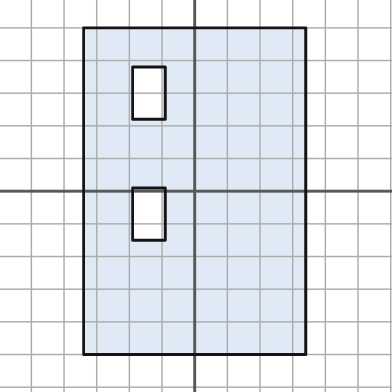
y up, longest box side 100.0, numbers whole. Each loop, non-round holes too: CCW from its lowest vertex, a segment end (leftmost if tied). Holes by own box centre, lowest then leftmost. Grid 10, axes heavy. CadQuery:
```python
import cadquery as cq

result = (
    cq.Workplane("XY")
    .moveTo(-34.0, -50.0)
    .lineTo(34.0, -50.0)
    .lineTo(34.0, 50.0)
    .lineTo(-34.0, 50.0)
    .close()
    .moveTo(-19.0, -15.0)
    .lineTo(-9.0, -15.0)
    .lineTo(-9.0, 1.0)
    .lineTo(-19.0, 1.0)
    .close()
    .moveTo(-19.0, 22.0)
    .lineTo(-9.0, 22.0)
    .lineTo(-9.0, 38.0)
    .lineTo(-19.0, 38.0)
    .close()
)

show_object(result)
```